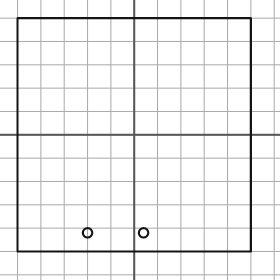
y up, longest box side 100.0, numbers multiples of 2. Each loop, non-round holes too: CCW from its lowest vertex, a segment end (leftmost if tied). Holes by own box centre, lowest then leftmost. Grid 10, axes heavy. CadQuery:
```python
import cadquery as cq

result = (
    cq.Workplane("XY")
    .moveTo(-50.0, -50.0)
    .lineTo(50.0, -50.0)
    .lineTo(50.0, 50.0)
    .lineTo(-50.0, 50.0)
    .close()
    .moveTo(-20.0, -42.0)
    .circle(2.0)
    .moveTo(4.0, -42.0)
    .circle(2.0)
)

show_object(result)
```